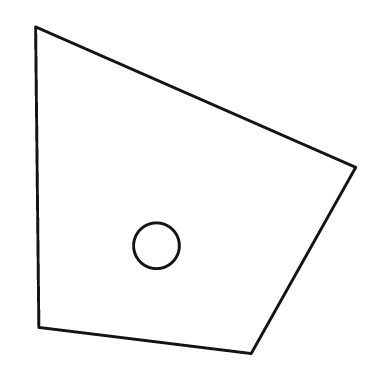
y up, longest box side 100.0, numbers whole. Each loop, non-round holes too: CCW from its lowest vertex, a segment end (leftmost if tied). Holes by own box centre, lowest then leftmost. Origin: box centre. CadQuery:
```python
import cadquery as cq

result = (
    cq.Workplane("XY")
    .moveTo(17.0, -50.0)
    .lineTo(49.0, 7.0)
    .lineTo(-49.0, 50.0)
    .lineTo(-48.0, -42.0)
    .close()
    .moveTo(-12.0, -17.0)
    .circle(7.0)
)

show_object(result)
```